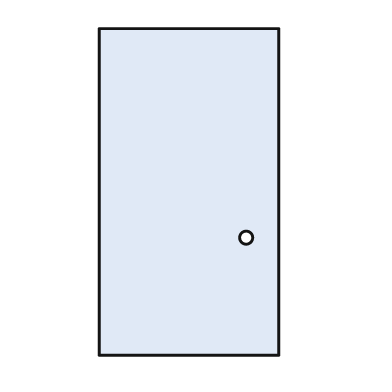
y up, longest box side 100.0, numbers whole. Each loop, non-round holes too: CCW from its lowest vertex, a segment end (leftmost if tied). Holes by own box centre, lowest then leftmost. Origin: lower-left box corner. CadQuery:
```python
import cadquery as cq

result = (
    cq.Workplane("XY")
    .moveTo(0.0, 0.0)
    .lineTo(55.0, 0.0)
    .lineTo(55.0, 100.0)
    .lineTo(0.0, 100.0)
    .close()
    .moveTo(45.0, 36.0)
    .circle(2.0)
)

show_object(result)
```